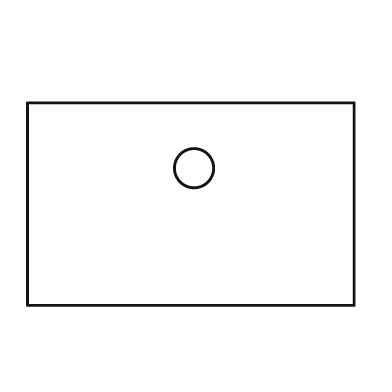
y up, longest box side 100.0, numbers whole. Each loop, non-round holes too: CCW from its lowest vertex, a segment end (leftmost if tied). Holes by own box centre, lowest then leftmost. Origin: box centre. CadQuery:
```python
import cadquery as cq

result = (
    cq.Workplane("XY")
    .moveTo(-50.0, -31.0)
    .lineTo(50.0, -31.0)
    .lineTo(50.0, 31.0)
    .lineTo(-50.0, 31.0)
    .close()
    .moveTo(1.0, 11.0)
    .circle(6.0)
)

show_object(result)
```